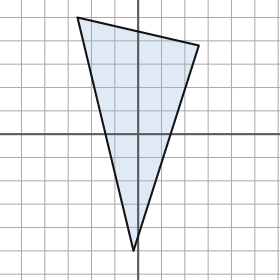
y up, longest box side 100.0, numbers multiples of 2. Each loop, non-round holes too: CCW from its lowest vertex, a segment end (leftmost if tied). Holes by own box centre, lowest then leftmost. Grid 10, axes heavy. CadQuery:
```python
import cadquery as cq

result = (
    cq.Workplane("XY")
    .moveTo(-2.0, -50.0)
    .lineTo(26.0, 38.0)
    .lineTo(-26.0, 50.0)
    .close()
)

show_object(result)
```